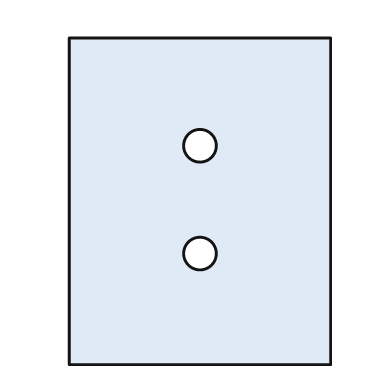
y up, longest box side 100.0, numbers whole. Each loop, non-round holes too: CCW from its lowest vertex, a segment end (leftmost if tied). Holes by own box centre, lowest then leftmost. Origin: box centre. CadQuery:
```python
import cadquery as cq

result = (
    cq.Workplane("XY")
    .moveTo(-40.0, -50.0)
    .lineTo(40.0, -50.0)
    .lineTo(40.0, 50.0)
    .lineTo(-40.0, 50.0)
    .close()
    .moveTo(0.0, -16.0)
    .circle(5.0)
    .moveTo(0.0, 17.0)
    .circle(5.0)
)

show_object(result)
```